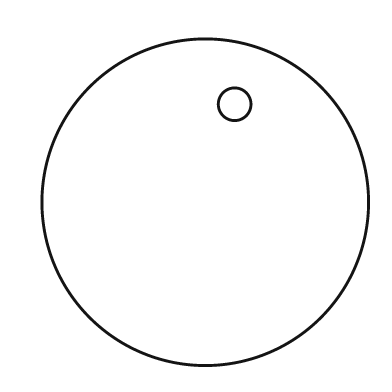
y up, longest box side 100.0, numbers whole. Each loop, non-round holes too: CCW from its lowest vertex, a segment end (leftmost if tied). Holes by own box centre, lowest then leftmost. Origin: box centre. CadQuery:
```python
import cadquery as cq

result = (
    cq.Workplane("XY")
    .moveTo(0.0, 0.0)
    .circle(50.0)
    .moveTo(9.0, 30.0)
    .circle(5.0)
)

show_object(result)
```